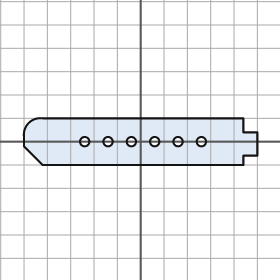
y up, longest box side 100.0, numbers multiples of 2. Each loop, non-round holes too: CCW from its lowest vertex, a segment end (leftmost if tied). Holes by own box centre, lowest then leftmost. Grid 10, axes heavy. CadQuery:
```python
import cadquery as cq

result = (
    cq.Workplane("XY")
    .moveTo(-42.0, -10.0)
    .lineTo(44.0, -10.0)
    .lineTo(44.0, -6.0)
    .lineTo(50.0, -6.0)
    .lineTo(50.0, 4.0)
    .lineTo(44.0, 4.0)
    .lineTo(44.0, 10.0)
    .lineTo(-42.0, 10.0)
    .threePointArc((-48.0, 8.0), (-50.0, 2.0))
    .lineTo(-50.0, -2.0)
    .close()
    .moveTo(-24.0, 0.0)
    .circle(2.0)
    .moveTo(-14.0, 0.0)
    .circle(2.0)
    .moveTo(-4.0, 0.0)
    .circle(2.0)
    .moveTo(6.0, 0.0)
    .circle(2.0)
    .moveTo(16.0, 0.0)
    .circle(2.0)
    .moveTo(26.0, 0.0)
    .circle(2.0)
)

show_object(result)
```